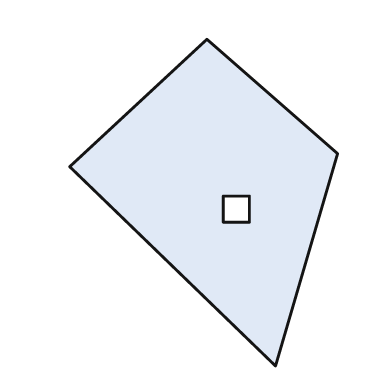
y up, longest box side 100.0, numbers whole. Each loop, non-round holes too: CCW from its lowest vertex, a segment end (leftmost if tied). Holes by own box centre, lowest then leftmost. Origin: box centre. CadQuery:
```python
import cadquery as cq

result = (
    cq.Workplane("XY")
    .moveTo(22.0, -50.0)
    .lineTo(41.0, 15.0)
    .lineTo(1.0, 50.0)
    .lineTo(-41.0, 11.0)
    .close()
    .moveTo(6.0, -6.0)
    .lineTo(14.0, -6.0)
    .lineTo(14.0, 2.0)
    .lineTo(6.0, 2.0)
    .close()
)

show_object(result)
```